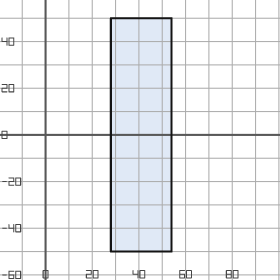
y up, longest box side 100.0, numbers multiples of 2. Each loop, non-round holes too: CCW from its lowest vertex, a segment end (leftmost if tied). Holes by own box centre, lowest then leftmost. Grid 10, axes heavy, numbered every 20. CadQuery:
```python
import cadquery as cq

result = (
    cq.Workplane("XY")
    .moveTo(28.0, -50.0)
    .lineTo(54.0, -50.0)
    .lineTo(54.0, 50.0)
    .lineTo(28.0, 50.0)
    .close()
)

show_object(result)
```